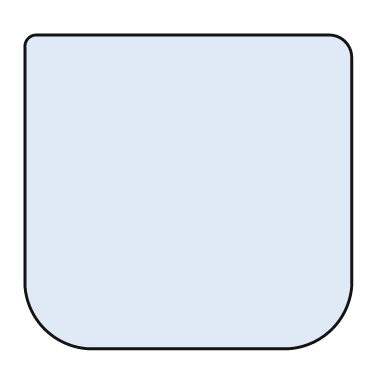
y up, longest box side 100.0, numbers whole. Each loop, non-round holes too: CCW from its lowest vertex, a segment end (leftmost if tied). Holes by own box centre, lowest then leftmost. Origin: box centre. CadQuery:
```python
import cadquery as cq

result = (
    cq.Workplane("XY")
    .moveTo(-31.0, -48.0)
    .lineTo(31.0, -48.0)
    .threePointArc((44.0, -42.0), (50.0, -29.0))
    .lineTo(50.0, 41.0)
    .threePointArc((48.0, 46.0), (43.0, 48.0))
    .lineTo(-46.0, 48.0)
    .threePointArc((-49.0, 47.0), (-50.0, 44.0))
    .lineTo(-50.0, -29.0)
    .threePointArc((-44.0, -42.0), (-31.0, -48.0))
    .close()
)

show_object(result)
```